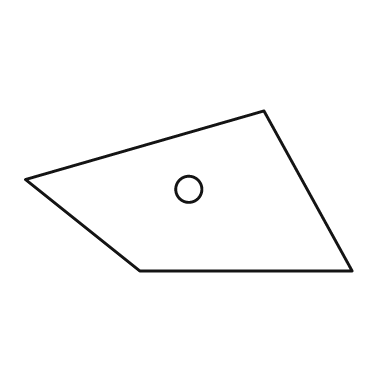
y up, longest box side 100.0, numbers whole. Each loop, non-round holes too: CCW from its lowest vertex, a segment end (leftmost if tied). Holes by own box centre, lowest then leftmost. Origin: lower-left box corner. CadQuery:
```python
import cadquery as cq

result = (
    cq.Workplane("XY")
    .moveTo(35.0, 0.0)
    .lineTo(100.0, 0.0)
    .lineTo(73.0, 49.0)
    .lineTo(0.0, 28.0)
    .close()
    .moveTo(50.0, 25.0)
    .circle(4.0)
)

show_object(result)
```